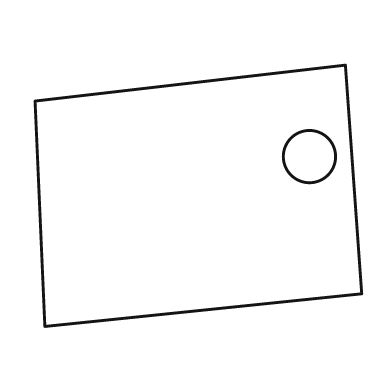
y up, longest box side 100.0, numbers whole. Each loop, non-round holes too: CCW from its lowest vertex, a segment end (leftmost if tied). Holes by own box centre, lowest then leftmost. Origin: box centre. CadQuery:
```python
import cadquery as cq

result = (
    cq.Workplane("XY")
    .moveTo(-47.0, -40.0)
    .lineTo(50.0, -30.0)
    .lineTo(45.0, 40.0)
    .lineTo(-50.0, 29.0)
    .close()
    .moveTo(34.0, 12.0)
    .circle(8.0)
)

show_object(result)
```